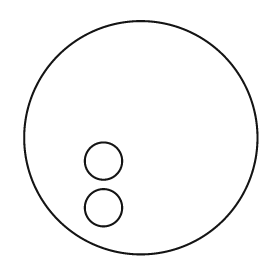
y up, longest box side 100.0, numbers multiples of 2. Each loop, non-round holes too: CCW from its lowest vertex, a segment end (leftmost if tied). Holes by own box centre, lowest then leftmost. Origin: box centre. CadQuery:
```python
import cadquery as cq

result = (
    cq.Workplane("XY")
    .moveTo(0.0, 0.0)
    .circle(50.0)
    .moveTo(-16.0, -30.0)
    .circle(8.0)
    .moveTo(-16.0, -10.0)
    .circle(8.0)
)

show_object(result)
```